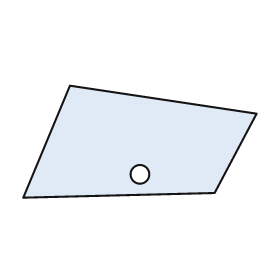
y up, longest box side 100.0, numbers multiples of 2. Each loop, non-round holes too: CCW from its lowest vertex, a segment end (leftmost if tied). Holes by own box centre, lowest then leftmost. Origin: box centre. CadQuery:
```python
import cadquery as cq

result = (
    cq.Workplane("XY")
    .moveTo(-50.0, -24.0)
    .lineTo(32.0, -22.0)
    .lineTo(50.0, 12.0)
    .lineTo(-30.0, 24.0)
    .close()
    .moveTo(0.0, -14.0)
    .circle(4.0)
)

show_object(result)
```